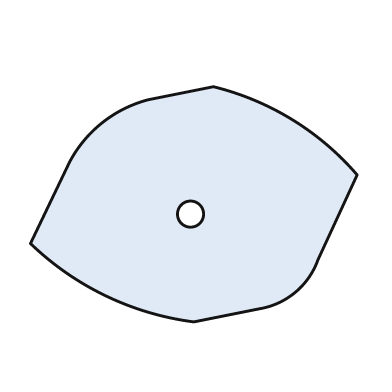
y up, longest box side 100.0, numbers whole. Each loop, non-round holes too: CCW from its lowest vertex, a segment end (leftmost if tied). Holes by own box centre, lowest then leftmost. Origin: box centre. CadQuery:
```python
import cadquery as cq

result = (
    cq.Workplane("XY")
    .moveTo(0.0, -36.0)
    .lineTo(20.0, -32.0)
    .threePointArc((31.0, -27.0), (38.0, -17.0))
    .lineTo(50.0, 9.0)
    .threePointArc((30.0, 26.0), (6.0, 36.0))
    .lineTo(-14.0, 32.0)
    .threePointArc((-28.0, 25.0), (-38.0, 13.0))
    .lineTo(-50.0, -12.0)
    .threePointArc((-27.0, -28.0), (0.0, -36.0))
    .close()
    .moveTo(-1.0, -3.0)
    .circle(4.0)
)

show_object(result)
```